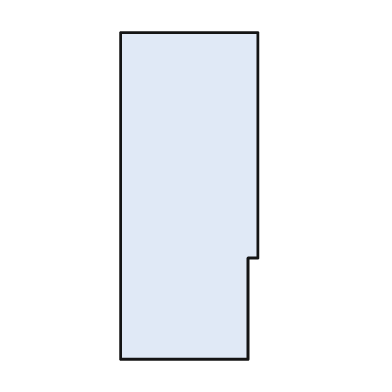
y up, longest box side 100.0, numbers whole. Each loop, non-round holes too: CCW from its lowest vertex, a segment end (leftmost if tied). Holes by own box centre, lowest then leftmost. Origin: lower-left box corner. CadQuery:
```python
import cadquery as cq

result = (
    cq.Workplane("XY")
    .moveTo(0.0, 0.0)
    .lineTo(39.0, 0.0)
    .lineTo(39.0, 31.0)
    .lineTo(42.0, 31.0)
    .lineTo(42.0, 100.0)
    .lineTo(0.0, 100.0)
    .close()
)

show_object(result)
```